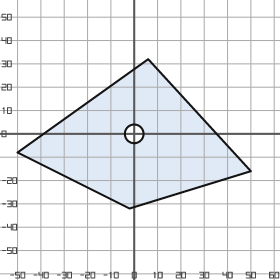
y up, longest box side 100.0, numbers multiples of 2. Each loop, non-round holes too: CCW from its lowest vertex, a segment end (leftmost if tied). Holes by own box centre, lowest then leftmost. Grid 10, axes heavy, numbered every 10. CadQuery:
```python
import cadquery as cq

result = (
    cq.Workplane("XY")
    .moveTo(-2.0, -32.0)
    .lineTo(50.0, -16.0)
    .lineTo(6.0, 32.0)
    .lineTo(-50.0, -8.0)
    .close()
    .moveTo(0.0, 0.0)
    .circle(4.0)
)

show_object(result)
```